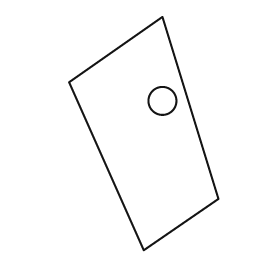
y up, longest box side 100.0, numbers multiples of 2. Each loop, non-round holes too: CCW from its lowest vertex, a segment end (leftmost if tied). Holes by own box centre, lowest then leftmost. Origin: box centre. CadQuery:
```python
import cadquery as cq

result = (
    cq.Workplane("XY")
    .moveTo(0.0, -50.0)
    .lineTo(32.0, -28.0)
    .lineTo(8.0, 50.0)
    .lineTo(-32.0, 22.0)
    .close()
    .moveTo(8.0, 14.0)
    .circle(6.0)
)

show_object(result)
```